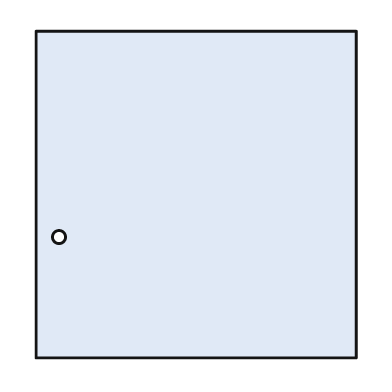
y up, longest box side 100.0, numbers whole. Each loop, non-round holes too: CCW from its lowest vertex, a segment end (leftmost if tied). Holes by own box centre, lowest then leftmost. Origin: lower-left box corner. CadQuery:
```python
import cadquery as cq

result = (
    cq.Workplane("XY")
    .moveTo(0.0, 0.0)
    .lineTo(98.0, 0.0)
    .lineTo(98.0, 100.0)
    .lineTo(0.0, 100.0)
    .close()
    .moveTo(7.0, 37.0)
    .circle(2.0)
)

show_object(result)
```